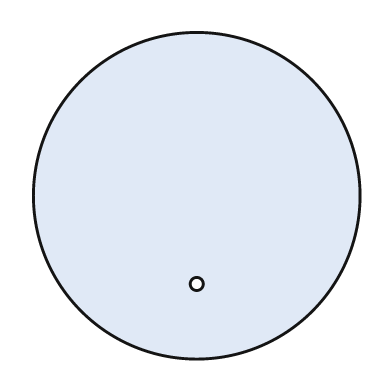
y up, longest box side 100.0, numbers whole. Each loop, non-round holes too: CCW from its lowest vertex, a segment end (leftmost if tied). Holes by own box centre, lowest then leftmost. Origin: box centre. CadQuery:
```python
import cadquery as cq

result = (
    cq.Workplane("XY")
    .moveTo(0.0, 0.0)
    .circle(50.0)
    .moveTo(0.0, -27.0)
    .circle(2.0)
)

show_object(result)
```